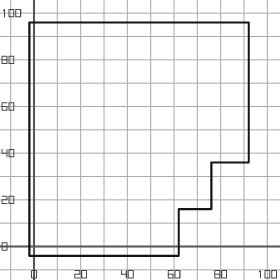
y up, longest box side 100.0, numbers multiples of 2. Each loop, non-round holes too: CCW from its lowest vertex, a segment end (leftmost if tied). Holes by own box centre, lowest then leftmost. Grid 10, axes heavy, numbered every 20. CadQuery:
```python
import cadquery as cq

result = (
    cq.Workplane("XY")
    .moveTo(-2.0, -4.0)
    .lineTo(62.0, -4.0)
    .lineTo(62.0, 16.0)
    .lineTo(76.0, 16.0)
    .lineTo(76.0, 36.0)
    .lineTo(92.0, 36.0)
    .lineTo(92.0, 96.0)
    .lineTo(-2.0, 96.0)
    .close()
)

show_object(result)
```